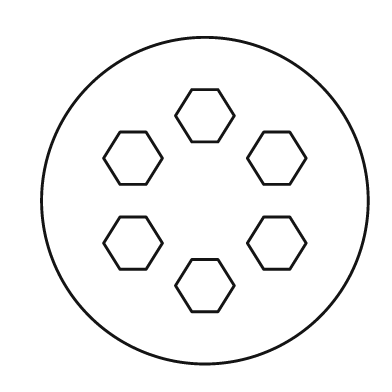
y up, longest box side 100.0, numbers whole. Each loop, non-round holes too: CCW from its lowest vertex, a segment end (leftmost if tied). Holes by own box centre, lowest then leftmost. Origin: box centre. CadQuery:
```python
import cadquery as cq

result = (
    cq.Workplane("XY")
    .moveTo(0.0, 0.0)
    .circle(50.0)
    .moveTo(-4.0, -34.0)
    .lineTo(4.0, -34.0)
    .lineTo(9.0, -26.0)
    .lineTo(4.0, -18.0)
    .lineTo(-4.0, -18.0)
    .lineTo(-9.0, -26.0)
    .close()
    .moveTo(-26.0, -21.0)
    .lineTo(-18.0, -21.0)
    .lineTo(-13.0, -13.0)
    .lineTo(-18.0, -5.0)
    .lineTo(-26.0, -5.0)
    .lineTo(-31.0, -13.0)
    .close()
    .moveTo(18.0, -21.0)
    .lineTo(26.0, -21.0)
    .lineTo(31.0, -13.0)
    .lineTo(26.0, -5.0)
    .lineTo(18.0, -5.0)
    .lineTo(13.0, -13.0)
    .close()
    .moveTo(-26.0, 5.0)
    .lineTo(-18.0, 5.0)
    .lineTo(-13.0, 13.0)
    .lineTo(-18.0, 21.0)
    .lineTo(-26.0, 21.0)
    .lineTo(-31.0, 13.0)
    .close()
    .moveTo(18.0, 5.0)
    .lineTo(26.0, 5.0)
    .lineTo(31.0, 13.0)
    .lineTo(26.0, 21.0)
    .lineTo(18.0, 21.0)
    .lineTo(13.0, 13.0)
    .close()
    .moveTo(-4.0, 18.0)
    .lineTo(4.0, 18.0)
    .lineTo(9.0, 26.0)
    .lineTo(4.0, 34.0)
    .lineTo(-4.0, 34.0)
    .lineTo(-9.0, 26.0)
    .close()
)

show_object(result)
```